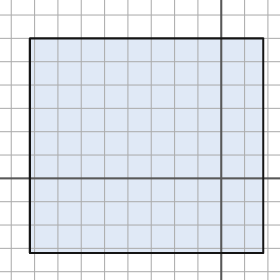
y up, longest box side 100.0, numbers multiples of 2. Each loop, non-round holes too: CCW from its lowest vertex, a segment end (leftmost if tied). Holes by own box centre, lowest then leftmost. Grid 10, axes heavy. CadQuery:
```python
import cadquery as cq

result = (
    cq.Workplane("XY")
    .moveTo(-82.0, -32.0)
    .lineTo(18.0, -32.0)
    .lineTo(18.0, 60.0)
    .lineTo(-82.0, 60.0)
    .close()
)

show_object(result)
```